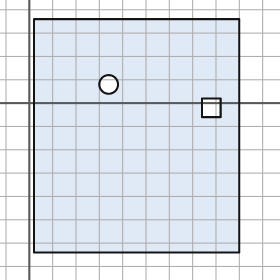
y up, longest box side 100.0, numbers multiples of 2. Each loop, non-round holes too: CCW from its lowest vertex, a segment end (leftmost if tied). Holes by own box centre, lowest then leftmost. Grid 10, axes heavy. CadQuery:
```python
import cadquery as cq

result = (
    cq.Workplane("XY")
    .moveTo(2.0, -64.0)
    .lineTo(90.0, -64.0)
    .lineTo(90.0, 36.0)
    .lineTo(2.0, 36.0)
    .close()
    .moveTo(74.0, -6.0)
    .lineTo(82.0, -6.0)
    .lineTo(82.0, 2.0)
    .lineTo(74.0, 2.0)
    .close()
    .moveTo(34.0, 8.0)
    .circle(4.0)
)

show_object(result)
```